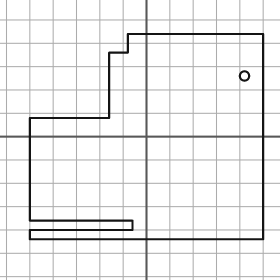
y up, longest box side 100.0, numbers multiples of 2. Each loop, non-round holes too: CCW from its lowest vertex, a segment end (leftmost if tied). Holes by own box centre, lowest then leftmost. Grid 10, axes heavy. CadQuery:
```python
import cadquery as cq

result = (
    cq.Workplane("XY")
    .moveTo(-50.0, -44.0)
    .lineTo(50.0, -44.0)
    .lineTo(50.0, 44.0)
    .lineTo(-8.0, 44.0)
    .lineTo(-8.0, 36.0)
    .lineTo(-16.0, 36.0)
    .lineTo(-16.0, 8.0)
    .lineTo(-50.0, 8.0)
    .lineTo(-50.0, -36.0)
    .lineTo(-6.0, -36.0)
    .lineTo(-6.0, -40.0)
    .lineTo(-50.0, -40.0)
    .close()
    .moveTo(42.0, 26.0)
    .circle(2.0)
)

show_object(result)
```